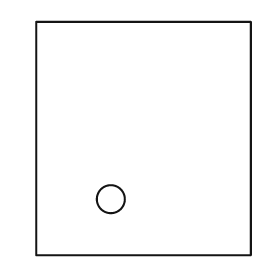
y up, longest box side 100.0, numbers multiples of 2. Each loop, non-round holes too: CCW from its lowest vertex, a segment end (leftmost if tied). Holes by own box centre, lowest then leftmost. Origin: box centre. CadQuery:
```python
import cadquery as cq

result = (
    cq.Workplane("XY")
    .moveTo(-46.0, -50.0)
    .lineTo(46.0, -50.0)
    .lineTo(46.0, 50.0)
    .lineTo(-46.0, 50.0)
    .close()
    .moveTo(-14.0, -26.0)
    .circle(6.0)
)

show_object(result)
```